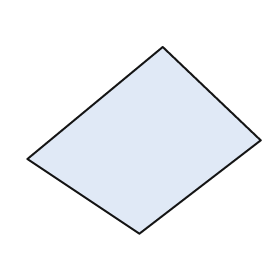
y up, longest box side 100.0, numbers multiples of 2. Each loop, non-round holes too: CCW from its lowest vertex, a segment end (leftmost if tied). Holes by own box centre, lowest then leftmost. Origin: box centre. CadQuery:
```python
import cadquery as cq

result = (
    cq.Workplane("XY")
    .moveTo(-2.0, -40.0)
    .lineTo(50.0, 0.0)
    .lineTo(8.0, 40.0)
    .lineTo(-50.0, -8.0)
    .close()
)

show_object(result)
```